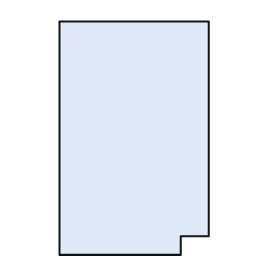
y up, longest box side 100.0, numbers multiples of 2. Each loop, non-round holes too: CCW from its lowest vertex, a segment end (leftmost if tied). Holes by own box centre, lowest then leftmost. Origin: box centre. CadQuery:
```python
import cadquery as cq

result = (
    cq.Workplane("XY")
    .moveTo(-32.0, -50.0)
    .lineTo(20.0, -50.0)
    .lineTo(20.0, -42.0)
    .lineTo(32.0, -42.0)
    .lineTo(32.0, 50.0)
    .lineTo(-32.0, 50.0)
    .close()
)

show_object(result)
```